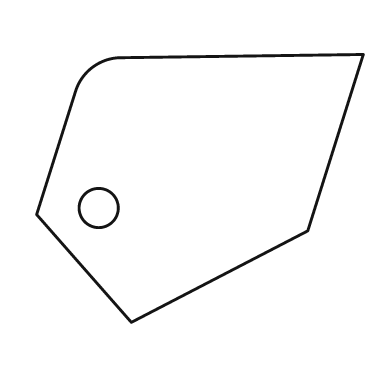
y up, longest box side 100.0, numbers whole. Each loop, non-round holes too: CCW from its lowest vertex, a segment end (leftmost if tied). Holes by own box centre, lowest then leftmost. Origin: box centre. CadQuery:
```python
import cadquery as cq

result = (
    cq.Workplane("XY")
    .moveTo(-21.0, -41.0)
    .lineTo(33.0, -13.0)
    .lineTo(50.0, 41.0)
    .lineTo(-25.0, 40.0)
    .threePointArc((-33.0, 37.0), (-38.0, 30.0))
    .lineTo(-50.0, -8.0)
    .close()
    .moveTo(-31.0, -6.0)
    .circle(6.0)
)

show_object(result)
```